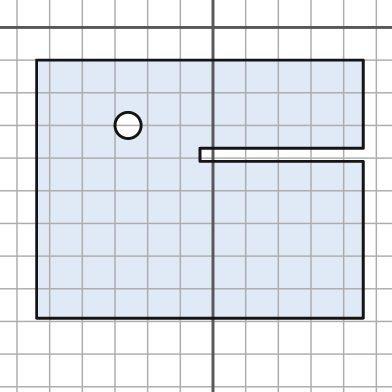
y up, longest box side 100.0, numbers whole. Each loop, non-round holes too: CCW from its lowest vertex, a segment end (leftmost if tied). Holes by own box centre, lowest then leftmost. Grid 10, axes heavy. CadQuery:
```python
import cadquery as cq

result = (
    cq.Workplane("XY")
    .moveTo(-54.0, -89.0)
    .lineTo(46.0, -89.0)
    .lineTo(46.0, -41.0)
    .lineTo(-4.0, -41.0)
    .lineTo(-4.0, -37.0)
    .lineTo(46.0, -37.0)
    .lineTo(46.0, -10.0)
    .lineTo(-54.0, -10.0)
    .close()
    .moveTo(-26.0, -30.0)
    .circle(4.0)
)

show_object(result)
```